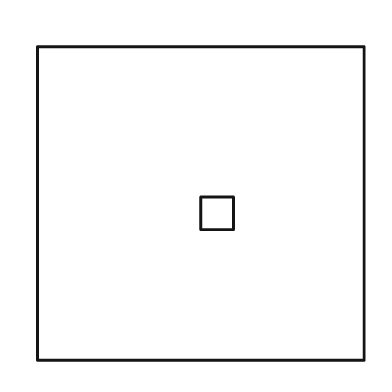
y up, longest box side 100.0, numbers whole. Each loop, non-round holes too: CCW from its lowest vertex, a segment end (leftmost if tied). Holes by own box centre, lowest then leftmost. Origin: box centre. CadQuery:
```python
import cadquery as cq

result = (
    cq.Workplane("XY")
    .moveTo(-50.0, -48.0)
    .lineTo(50.0, -48.0)
    .lineTo(50.0, 48.0)
    .lineTo(-50.0, 48.0)
    .close()
    .moveTo(0.0, -8.0)
    .lineTo(10.0, -8.0)
    .lineTo(10.0, 2.0)
    .lineTo(0.0, 2.0)
    .close()
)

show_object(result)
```